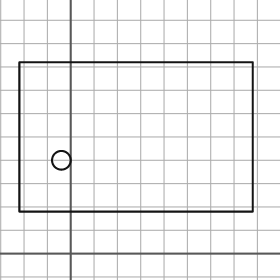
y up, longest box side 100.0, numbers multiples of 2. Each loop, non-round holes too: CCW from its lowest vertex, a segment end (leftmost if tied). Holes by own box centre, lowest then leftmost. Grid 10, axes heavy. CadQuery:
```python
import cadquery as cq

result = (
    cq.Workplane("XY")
    .moveTo(-22.0, 18.0)
    .lineTo(78.0, 18.0)
    .lineTo(78.0, 82.0)
    .lineTo(-22.0, 82.0)
    .close()
    .moveTo(-4.0, 40.0)
    .circle(4.0)
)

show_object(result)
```